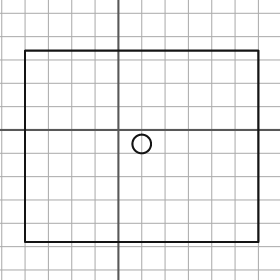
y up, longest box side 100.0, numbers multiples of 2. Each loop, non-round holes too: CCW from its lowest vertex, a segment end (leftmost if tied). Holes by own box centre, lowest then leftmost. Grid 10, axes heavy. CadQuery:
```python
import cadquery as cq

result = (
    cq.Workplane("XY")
    .moveTo(-40.0, -48.0)
    .lineTo(60.0, -48.0)
    .lineTo(60.0, 34.0)
    .lineTo(-40.0, 34.0)
    .close()
    .moveTo(10.0, -6.0)
    .circle(4.0)
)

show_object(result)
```